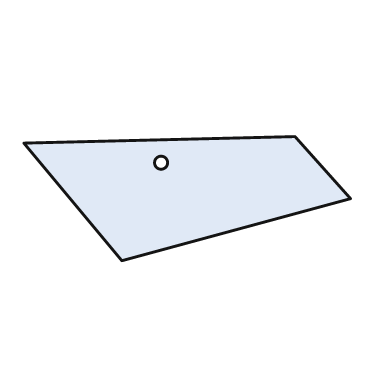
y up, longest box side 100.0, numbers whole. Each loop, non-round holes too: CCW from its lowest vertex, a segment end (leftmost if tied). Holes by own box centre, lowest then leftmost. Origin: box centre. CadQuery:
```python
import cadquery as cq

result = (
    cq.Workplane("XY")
    .moveTo(-20.0, -19.0)
    .lineTo(50.0, 0.0)
    .lineTo(33.0, 19.0)
    .lineTo(-50.0, 17.0)
    .close()
    .moveTo(-8.0, 11.0)
    .circle(2.0)
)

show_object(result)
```